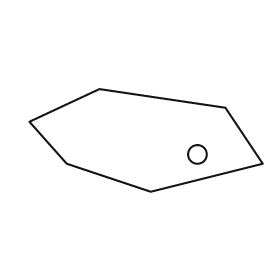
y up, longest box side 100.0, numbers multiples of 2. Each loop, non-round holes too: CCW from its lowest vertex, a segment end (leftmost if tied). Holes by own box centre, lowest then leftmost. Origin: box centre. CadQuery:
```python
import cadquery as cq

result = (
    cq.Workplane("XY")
    .moveTo(2.0, -22.0)
    .lineTo(50.0, -10.0)
    .lineTo(34.0, 14.0)
    .lineTo(-20.0, 22.0)
    .lineTo(-50.0, 8.0)
    .lineTo(-34.0, -10.0)
    .close()
    .moveTo(22.0, -6.0)
    .circle(4.0)
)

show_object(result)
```